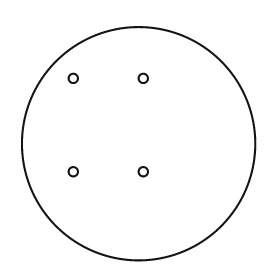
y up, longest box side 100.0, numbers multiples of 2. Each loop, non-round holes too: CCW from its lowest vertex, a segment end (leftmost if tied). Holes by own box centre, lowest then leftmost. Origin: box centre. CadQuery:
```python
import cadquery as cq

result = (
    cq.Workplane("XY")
    .moveTo(0.0, 0.0)
    .circle(50.0)
    .moveTo(-28.0, -12.0)
    .circle(2.0)
    .moveTo(2.0, -12.0)
    .circle(2.0)
    .moveTo(-28.0, 28.0)
    .circle(2.0)
    .moveTo(2.0, 28.0)
    .circle(2.0)
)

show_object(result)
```